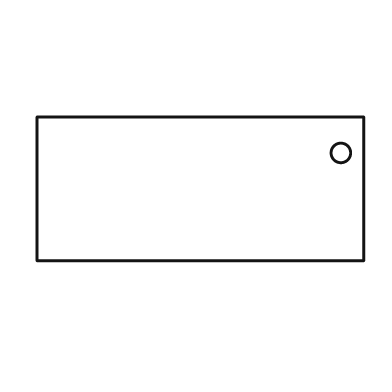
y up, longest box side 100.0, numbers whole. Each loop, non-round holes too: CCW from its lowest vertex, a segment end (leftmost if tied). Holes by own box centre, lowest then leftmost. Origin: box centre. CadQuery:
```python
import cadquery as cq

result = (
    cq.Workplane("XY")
    .moveTo(-50.0, -22.0)
    .lineTo(50.0, -22.0)
    .lineTo(50.0, 22.0)
    .lineTo(-50.0, 22.0)
    .close()
    .moveTo(43.0, 11.0)
    .circle(3.0)
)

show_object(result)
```